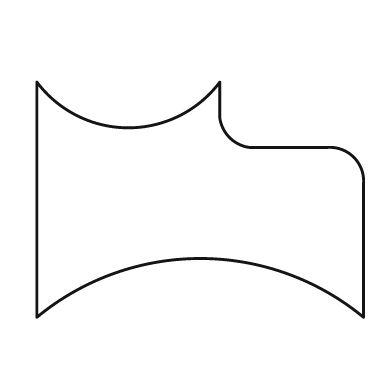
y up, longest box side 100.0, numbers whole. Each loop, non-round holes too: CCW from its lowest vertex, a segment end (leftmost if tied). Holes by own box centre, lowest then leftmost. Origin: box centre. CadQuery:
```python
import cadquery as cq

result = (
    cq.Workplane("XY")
    .moveTo(-50.0, -36.0)
    .threePointArc((0.0, -18.0), (50.0, -36.0))
    .lineTo(50.0, 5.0)
    .threePointArc((47.0, 13.0), (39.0, 16.0))
    .lineTo(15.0, 16.0)
    .threePointArc((9.0, 19.0), (6.0, 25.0))
    .lineTo(6.0, 36.0)
    .threePointArc((-22.0, 22.0), (-50.0, 36.0))
    .close()
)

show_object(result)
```